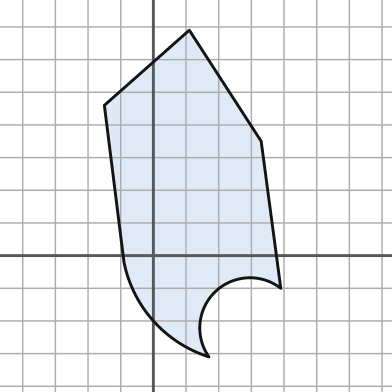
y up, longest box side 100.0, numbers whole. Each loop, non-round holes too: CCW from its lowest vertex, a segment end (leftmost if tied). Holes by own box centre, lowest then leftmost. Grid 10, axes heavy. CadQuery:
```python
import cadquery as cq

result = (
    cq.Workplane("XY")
    .moveTo(17.0, -31.0)
    .threePointArc((19.0, -11.0), (39.0, -10.0))
    .lineTo(33.0, 35.0)
    .lineTo(11.0, 69.0)
    .lineTo(-15.0, 46.0)
    .lineTo(-9.0, -2.0)
    .threePointArc((0.0, -20.0), (17.0, -31.0))
    .close()
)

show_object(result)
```